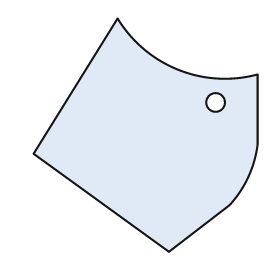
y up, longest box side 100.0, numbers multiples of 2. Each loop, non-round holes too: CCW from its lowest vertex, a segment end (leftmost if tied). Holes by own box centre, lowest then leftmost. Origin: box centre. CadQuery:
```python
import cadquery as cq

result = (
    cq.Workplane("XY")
    .moveTo(10.0, -50.0)
    .lineTo(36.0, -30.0)
    .threePointArc((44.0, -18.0), (48.0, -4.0))
    .lineTo(48.0, 26.0)
    .threePointArc((14.0, 28.0), (-12.0, 50.0))
    .lineTo(-48.0, -8.0)
    .close()
    .moveTo(30.0, 14.0)
    .circle(4.0)
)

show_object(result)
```